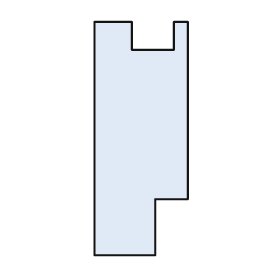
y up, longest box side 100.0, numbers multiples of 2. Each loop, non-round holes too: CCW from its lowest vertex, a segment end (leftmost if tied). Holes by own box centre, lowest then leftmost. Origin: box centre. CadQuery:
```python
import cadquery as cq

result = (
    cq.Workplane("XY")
    .moveTo(-20.0, -50.0)
    .lineTo(6.0, -50.0)
    .lineTo(6.0, -26.0)
    .lineTo(20.0, -26.0)
    .lineTo(20.0, 50.0)
    .lineTo(14.0, 50.0)
    .lineTo(14.0, 38.0)
    .lineTo(-4.0, 38.0)
    .lineTo(-4.0, 50.0)
    .lineTo(-20.0, 50.0)
    .close()
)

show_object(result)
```